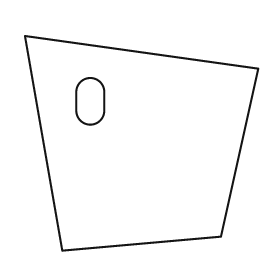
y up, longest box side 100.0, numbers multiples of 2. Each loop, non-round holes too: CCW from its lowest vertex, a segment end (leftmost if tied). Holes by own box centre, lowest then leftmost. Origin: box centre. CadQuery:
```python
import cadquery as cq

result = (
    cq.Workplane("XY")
    .moveTo(-34.0, -46.0)
    .lineTo(34.0, -40.0)
    .lineTo(50.0, 32.0)
    .lineTo(-50.0, 46.0)
    .close()
    .moveTo(-28.0, 14.0)
    .threePointArc((-22.0, 8.0), (-16.0, 14.0))
    .lineTo(-16.0, 22.0)
    .threePointArc((-22.0, 28.0), (-28.0, 22.0))
    .close()
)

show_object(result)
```